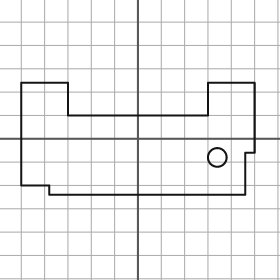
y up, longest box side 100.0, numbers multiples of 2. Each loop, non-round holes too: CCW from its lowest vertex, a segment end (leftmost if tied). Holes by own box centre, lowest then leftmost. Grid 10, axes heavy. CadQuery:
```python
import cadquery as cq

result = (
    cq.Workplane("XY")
    .moveTo(-38.0, -24.0)
    .lineTo(46.0, -24.0)
    .lineTo(46.0, -6.0)
    .lineTo(50.0, -6.0)
    .lineTo(50.0, 24.0)
    .lineTo(30.0, 24.0)
    .lineTo(30.0, 10.0)
    .lineTo(-30.0, 10.0)
    .lineTo(-30.0, 24.0)
    .lineTo(-50.0, 24.0)
    .lineTo(-50.0, -20.0)
    .lineTo(-38.0, -20.0)
    .close()
    .moveTo(34.0, -8.0)
    .circle(4.0)
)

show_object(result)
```